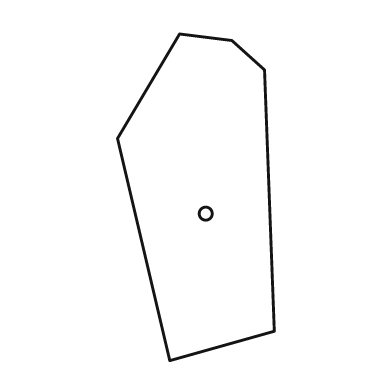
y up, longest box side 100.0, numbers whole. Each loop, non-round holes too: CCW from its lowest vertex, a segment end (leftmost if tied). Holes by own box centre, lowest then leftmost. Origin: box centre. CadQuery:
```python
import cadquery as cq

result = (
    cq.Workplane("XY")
    .moveTo(-8.0, -50.0)
    .lineTo(24.0, -41.0)
    .lineTo(21.0, 39.0)
    .lineTo(11.0, 48.0)
    .lineTo(-5.0, 50.0)
    .lineTo(-24.0, 18.0)
    .close()
    .moveTo(3.0, -5.0)
    .circle(2.0)
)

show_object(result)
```